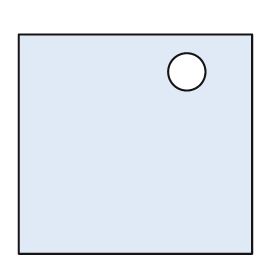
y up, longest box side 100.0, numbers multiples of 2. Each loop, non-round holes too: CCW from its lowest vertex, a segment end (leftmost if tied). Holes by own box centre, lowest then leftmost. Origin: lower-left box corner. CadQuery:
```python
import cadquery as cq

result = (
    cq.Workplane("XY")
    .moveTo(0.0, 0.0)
    .lineTo(100.0, 0.0)
    .lineTo(100.0, 94.0)
    .lineTo(0.0, 94.0)
    .close()
    .moveTo(72.0, 78.0)
    .circle(8.0)
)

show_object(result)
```